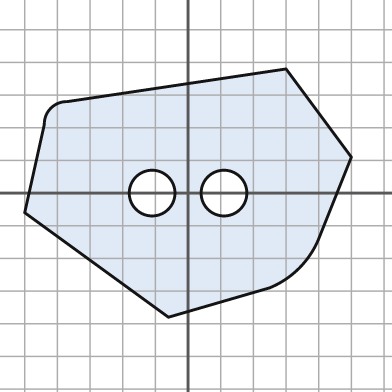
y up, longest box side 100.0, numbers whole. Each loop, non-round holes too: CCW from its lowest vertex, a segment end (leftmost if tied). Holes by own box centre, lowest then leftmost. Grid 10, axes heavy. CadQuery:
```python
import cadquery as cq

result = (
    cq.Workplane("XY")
    .moveTo(-6.0, -38.0)
    .lineTo(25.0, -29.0)
    .threePointArc((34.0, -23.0), (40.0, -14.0))
    .lineTo(50.0, 11.0)
    .lineTo(30.0, 38.0)
    .lineTo(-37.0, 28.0)
    .threePointArc((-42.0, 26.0), (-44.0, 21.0))
    .lineTo(-50.0, -6.0)
    .close()
    .moveTo(-11.0, 0.0)
    .circle(7.0)
    .moveTo(11.0, 0.0)
    .circle(7.0)
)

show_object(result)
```